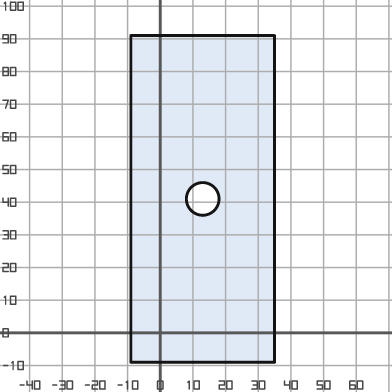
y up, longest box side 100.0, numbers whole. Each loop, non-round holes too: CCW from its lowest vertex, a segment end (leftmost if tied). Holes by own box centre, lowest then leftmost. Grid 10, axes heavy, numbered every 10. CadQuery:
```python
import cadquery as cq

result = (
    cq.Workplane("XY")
    .moveTo(-9.0, -9.0)
    .lineTo(35.0, -9.0)
    .lineTo(35.0, 91.0)
    .lineTo(-9.0, 91.0)
    .close()
    .moveTo(13.0, 41.0)
    .circle(5.0)
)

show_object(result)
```